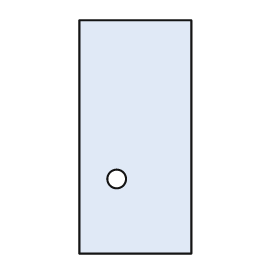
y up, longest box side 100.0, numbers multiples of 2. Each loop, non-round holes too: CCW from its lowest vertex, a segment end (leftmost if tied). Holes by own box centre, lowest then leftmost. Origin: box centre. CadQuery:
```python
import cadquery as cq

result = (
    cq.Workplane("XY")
    .moveTo(-24.0, -50.0)
    .lineTo(24.0, -50.0)
    .lineTo(24.0, 50.0)
    .lineTo(-24.0, 50.0)
    .close()
    .moveTo(-8.0, -18.0)
    .circle(4.0)
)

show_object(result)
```